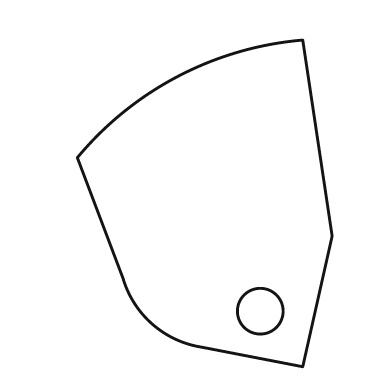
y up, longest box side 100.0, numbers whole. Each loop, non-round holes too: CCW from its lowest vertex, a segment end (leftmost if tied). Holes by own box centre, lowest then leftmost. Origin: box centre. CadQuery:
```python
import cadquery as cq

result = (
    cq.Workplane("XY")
    .moveTo(30.0, -50.0)
    .lineTo(39.0, -10.0)
    .lineTo(30.0, 50.0)
    .threePointArc((-8.0, 39.0), (-39.0, 14.0))
    .lineTo(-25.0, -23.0)
    .threePointArc((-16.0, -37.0), (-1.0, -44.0))
    .close()
    .moveTo(17.0, -33.0)
    .circle(7.0)
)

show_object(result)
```